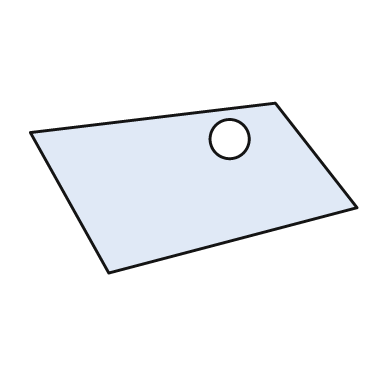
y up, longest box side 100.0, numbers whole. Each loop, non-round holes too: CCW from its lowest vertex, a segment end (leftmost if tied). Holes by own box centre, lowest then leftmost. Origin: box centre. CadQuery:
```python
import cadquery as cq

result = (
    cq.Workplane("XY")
    .moveTo(-26.0, -26.0)
    .lineTo(50.0, -6.0)
    .lineTo(25.0, 26.0)
    .lineTo(-50.0, 17.0)
    .close()
    .moveTo(11.0, 15.0)
    .circle(6.0)
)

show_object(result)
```